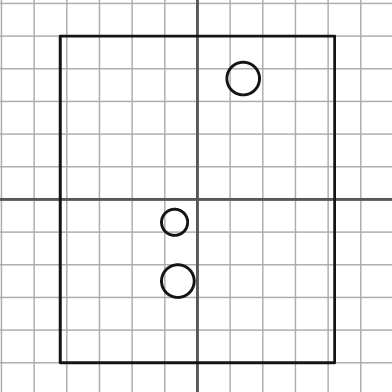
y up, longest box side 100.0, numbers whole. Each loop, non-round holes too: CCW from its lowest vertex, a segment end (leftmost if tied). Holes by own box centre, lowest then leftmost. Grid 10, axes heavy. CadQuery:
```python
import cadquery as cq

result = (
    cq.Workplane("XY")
    .moveTo(-42.0, -50.0)
    .lineTo(42.0, -50.0)
    .lineTo(42.0, 50.0)
    .lineTo(-42.0, 50.0)
    .close()
    .moveTo(-6.0, -25.0)
    .circle(5.0)
    .moveTo(-7.0, -7.0)
    .circle(4.0)
    .moveTo(14.0, 37.0)
    .circle(5.0)
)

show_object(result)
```